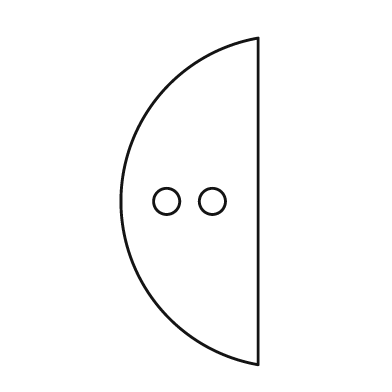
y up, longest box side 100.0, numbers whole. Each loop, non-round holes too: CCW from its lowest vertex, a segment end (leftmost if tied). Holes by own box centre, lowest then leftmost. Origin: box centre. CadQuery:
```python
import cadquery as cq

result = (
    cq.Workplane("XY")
    .moveTo(21.0, -50.0)
    .lineTo(21.0, 50.0)
    .threePointArc((-21.0, 0.0), (21.0, -50.0))
    .close()
    .moveTo(-7.0, 0.0)
    .circle(4.0)
    .moveTo(7.0, 0.0)
    .circle(4.0)
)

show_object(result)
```